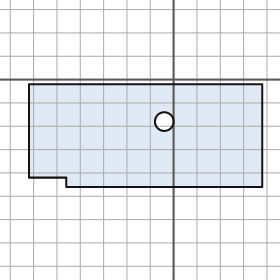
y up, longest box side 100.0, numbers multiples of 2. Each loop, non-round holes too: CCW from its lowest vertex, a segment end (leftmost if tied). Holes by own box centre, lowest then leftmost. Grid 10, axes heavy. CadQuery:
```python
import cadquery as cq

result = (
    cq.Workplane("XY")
    .moveTo(-46.0, -46.0)
    .lineTo(38.0, -46.0)
    .lineTo(38.0, -2.0)
    .lineTo(-62.0, -2.0)
    .lineTo(-62.0, -42.0)
    .lineTo(-46.0, -42.0)
    .close()
    .moveTo(-4.0, -18.0)
    .circle(4.0)
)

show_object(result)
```